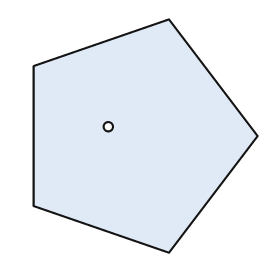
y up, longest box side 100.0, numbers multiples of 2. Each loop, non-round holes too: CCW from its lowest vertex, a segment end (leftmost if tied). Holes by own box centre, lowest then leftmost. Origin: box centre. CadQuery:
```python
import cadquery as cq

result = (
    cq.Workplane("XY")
    .moveTo(10.0, -50.0)
    .lineTo(48.0, 0.0)
    .lineTo(10.0, 50.0)
    .lineTo(-48.0, 30.0)
    .lineTo(-48.0, -30.0)
    .close()
    .moveTo(-16.0, 4.0)
    .circle(2.0)
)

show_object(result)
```